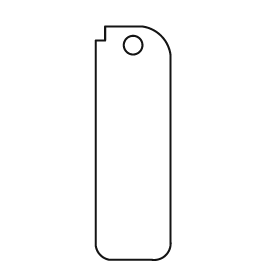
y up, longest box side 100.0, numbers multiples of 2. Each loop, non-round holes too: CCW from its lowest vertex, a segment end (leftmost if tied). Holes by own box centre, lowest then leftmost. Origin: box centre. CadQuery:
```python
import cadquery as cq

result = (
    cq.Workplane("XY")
    .moveTo(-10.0, -50.0)
    .lineTo(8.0, -50.0)
    .threePointArc((14.0, -48.0), (16.0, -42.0))
    .lineTo(16.0, 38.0)
    .threePointArc((12.0, 46.0), (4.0, 50.0))
    .lineTo(-12.0, 50.0)
    .lineTo(-12.0, 44.0)
    .lineTo(-16.0, 44.0)
    .lineTo(-16.0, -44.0)
    .threePointArc((-14.0, -48.0), (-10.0, -50.0))
    .close()
    .moveTo(0.0, 42.0)
    .circle(4.0)
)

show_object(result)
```